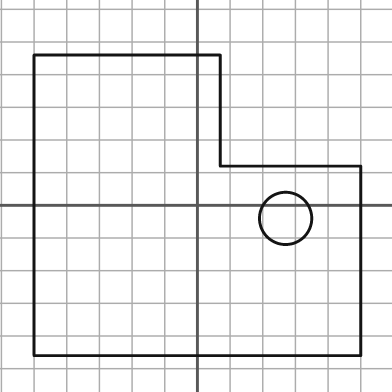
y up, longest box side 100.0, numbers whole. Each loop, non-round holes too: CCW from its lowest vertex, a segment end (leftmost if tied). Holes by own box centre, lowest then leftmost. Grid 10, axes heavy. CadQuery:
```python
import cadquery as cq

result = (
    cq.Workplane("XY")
    .moveTo(-50.0, -46.0)
    .lineTo(50.0, -46.0)
    .lineTo(50.0, 12.0)
    .lineTo(7.0, 12.0)
    .lineTo(7.0, 46.0)
    .lineTo(-50.0, 46.0)
    .close()
    .moveTo(27.0, -4.0)
    .circle(8.0)
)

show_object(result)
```